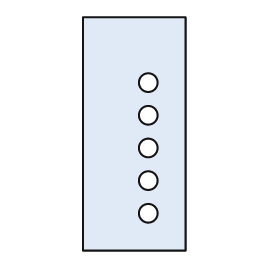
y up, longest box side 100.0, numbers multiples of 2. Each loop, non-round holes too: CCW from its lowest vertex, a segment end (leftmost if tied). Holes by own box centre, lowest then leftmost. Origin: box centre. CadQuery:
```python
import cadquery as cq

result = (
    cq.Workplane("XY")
    .moveTo(-22.0, -50.0)
    .lineTo(22.0, -50.0)
    .lineTo(22.0, 50.0)
    .lineTo(-22.0, 50.0)
    .close()
    .moveTo(6.0, -34.0)
    .circle(4.0)
    .moveTo(6.0, -20.0)
    .circle(4.0)
    .moveTo(6.0, -6.0)
    .circle(4.0)
    .moveTo(6.0, 8.0)
    .circle(4.0)
    .moveTo(6.0, 22.0)
    .circle(4.0)
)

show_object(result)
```